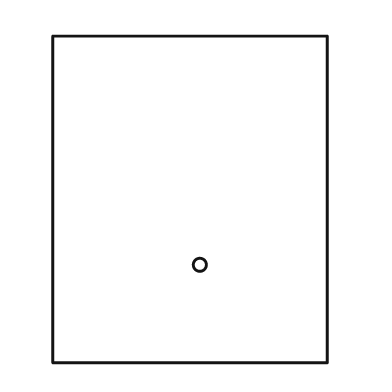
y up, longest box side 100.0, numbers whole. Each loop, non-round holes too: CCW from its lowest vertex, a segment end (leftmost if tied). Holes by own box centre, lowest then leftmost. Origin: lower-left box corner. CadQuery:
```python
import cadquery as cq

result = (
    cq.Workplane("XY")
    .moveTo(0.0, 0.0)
    .lineTo(84.0, 0.0)
    .lineTo(84.0, 100.0)
    .lineTo(0.0, 100.0)
    .close()
    .moveTo(45.0, 30.0)
    .circle(2.0)
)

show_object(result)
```